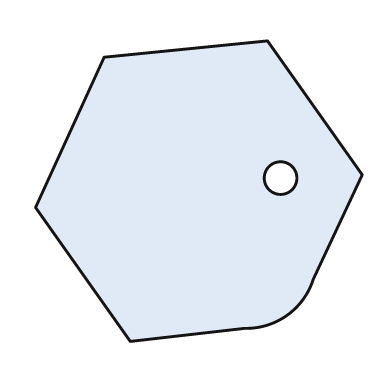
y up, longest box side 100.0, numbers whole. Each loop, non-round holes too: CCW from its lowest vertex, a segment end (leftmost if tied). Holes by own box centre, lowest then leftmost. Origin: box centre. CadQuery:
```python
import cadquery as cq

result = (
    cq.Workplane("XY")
    .moveTo(-21.0, -46.0)
    .lineTo(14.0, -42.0)
    .threePointArc((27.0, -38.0), (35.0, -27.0))
    .lineTo(50.0, 5.0)
    .lineTo(21.0, 46.0)
    .lineTo(-29.0, 41.0)
    .lineTo(-50.0, -5.0)
    .close()
    .moveTo(25.0, 4.0)
    .circle(5.0)
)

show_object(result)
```